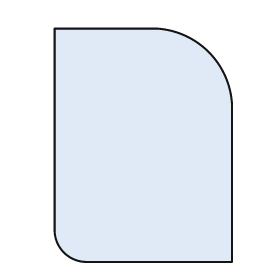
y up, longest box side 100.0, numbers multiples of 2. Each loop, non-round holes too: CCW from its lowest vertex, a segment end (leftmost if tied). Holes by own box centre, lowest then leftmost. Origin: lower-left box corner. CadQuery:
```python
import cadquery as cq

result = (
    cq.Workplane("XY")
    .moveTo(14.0, 0.0)
    .lineTo(76.0, 0.0)
    .lineTo(76.0, 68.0)
    .threePointArc((66.0, 90.0), (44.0, 100.0))
    .lineTo(0.0, 100.0)
    .lineTo(0.0, 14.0)
    .threePointArc((4.0, 4.0), (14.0, 0.0))
    .close()
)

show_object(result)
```